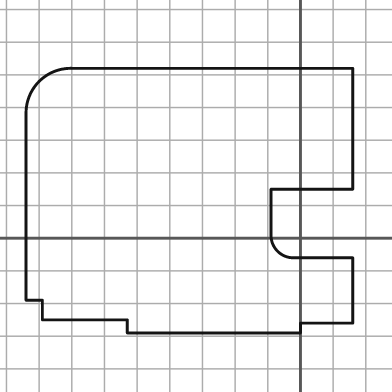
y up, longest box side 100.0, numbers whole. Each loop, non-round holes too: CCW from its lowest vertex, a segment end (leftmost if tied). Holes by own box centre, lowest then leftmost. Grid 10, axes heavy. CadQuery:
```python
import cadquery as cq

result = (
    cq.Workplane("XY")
    .moveTo(-53.0, -29.0)
    .lineTo(0.0, -29.0)
    .lineTo(0.0, -26.0)
    .lineTo(16.0, -26.0)
    .lineTo(16.0, -6.0)
    .lineTo(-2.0, -6.0)
    .threePointArc((-7.0, -4.0), (-9.0, 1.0))
    .lineTo(-9.0, 15.0)
    .lineTo(16.0, 15.0)
    .lineTo(16.0, 52.0)
    .lineTo(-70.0, 52.0)
    .threePointArc((-80.0, 48.0), (-84.0, 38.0))
    .lineTo(-84.0, -19.0)
    .lineTo(-79.0, -19.0)
    .lineTo(-79.0, -25.0)
    .lineTo(-53.0, -25.0)
    .close()
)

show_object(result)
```